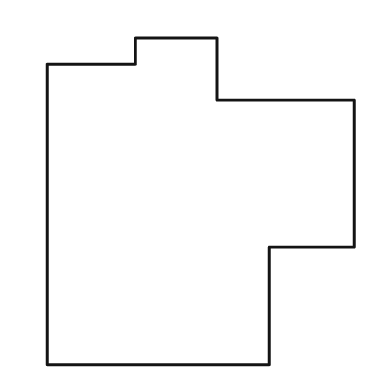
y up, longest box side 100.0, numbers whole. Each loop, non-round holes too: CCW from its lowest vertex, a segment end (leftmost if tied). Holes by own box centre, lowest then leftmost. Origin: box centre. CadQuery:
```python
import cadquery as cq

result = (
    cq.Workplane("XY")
    .moveTo(-47.0, -50.0)
    .lineTo(21.0, -50.0)
    .lineTo(21.0, -14.0)
    .lineTo(47.0, -14.0)
    .lineTo(47.0, 31.0)
    .lineTo(5.0, 31.0)
    .lineTo(5.0, 50.0)
    .lineTo(-20.0, 50.0)
    .lineTo(-20.0, 42.0)
    .lineTo(-47.0, 42.0)
    .close()
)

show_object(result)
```